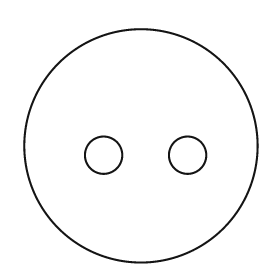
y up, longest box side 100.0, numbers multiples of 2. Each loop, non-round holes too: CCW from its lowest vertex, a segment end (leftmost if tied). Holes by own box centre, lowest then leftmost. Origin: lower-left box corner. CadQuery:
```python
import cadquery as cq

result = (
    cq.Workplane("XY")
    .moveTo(50.0, 50.0)
    .circle(50.0)
    .moveTo(34.0, 46.0)
    .circle(8.0)
    .moveTo(70.0, 46.0)
    .circle(8.0)
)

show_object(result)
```